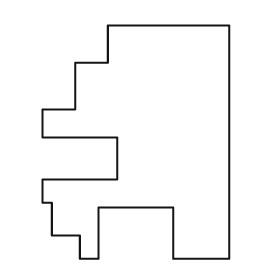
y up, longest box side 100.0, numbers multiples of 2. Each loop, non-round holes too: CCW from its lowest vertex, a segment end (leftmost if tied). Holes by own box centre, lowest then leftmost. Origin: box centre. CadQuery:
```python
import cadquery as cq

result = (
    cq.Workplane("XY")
    .moveTo(-24.0, -50.0)
    .lineTo(-16.0, -50.0)
    .lineTo(-16.0, -28.0)
    .lineTo(16.0, -28.0)
    .lineTo(16.0, -50.0)
    .lineTo(40.0, -50.0)
    .lineTo(40.0, 50.0)
    .lineTo(-12.0, 50.0)
    .lineTo(-12.0, 34.0)
    .lineTo(-26.0, 34.0)
    .lineTo(-26.0, 14.0)
    .lineTo(-40.0, 14.0)
    .lineTo(-40.0, 2.0)
    .lineTo(-8.0, 2.0)
    .lineTo(-8.0, -16.0)
    .lineTo(-40.0, -16.0)
    .lineTo(-40.0, -26.0)
    .lineTo(-36.0, -26.0)
    .lineTo(-36.0, -40.0)
    .lineTo(-24.0, -40.0)
    .close()
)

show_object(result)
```